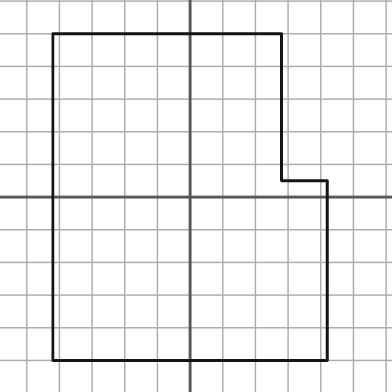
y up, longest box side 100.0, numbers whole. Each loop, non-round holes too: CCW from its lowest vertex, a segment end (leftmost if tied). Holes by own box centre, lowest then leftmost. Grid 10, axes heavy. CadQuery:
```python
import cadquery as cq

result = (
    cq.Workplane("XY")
    .moveTo(-42.0, -50.0)
    .lineTo(42.0, -50.0)
    .lineTo(42.0, 5.0)
    .lineTo(28.0, 5.0)
    .lineTo(28.0, 50.0)
    .lineTo(-42.0, 50.0)
    .close()
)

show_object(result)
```